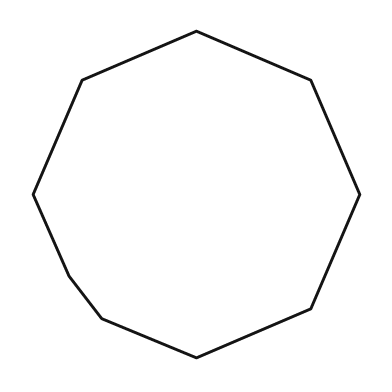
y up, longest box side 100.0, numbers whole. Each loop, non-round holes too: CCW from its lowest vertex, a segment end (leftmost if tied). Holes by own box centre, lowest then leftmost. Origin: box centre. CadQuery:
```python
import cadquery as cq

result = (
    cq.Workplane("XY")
    .moveTo(0.0, -50.0)
    .lineTo(35.0, -35.0)
    .lineTo(50.0, 0.0)
    .lineTo(35.0, 35.0)
    .lineTo(0.0, 50.0)
    .lineTo(-35.0, 35.0)
    .lineTo(-50.0, 0.0)
    .lineTo(-39.0, -25.0)
    .lineTo(-29.0, -38.0)
    .close()
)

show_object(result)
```